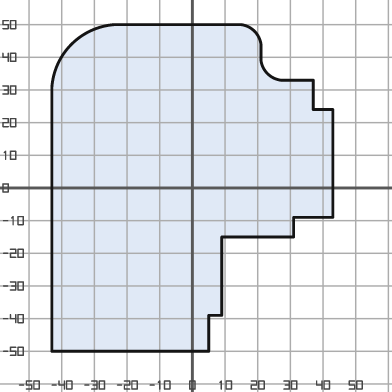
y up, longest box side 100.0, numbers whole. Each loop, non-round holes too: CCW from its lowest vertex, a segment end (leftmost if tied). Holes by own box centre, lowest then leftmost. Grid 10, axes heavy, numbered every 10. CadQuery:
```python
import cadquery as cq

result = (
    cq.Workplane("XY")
    .moveTo(-43.0, -50.0)
    .lineTo(5.0, -50.0)
    .lineTo(5.0, -39.0)
    .lineTo(9.0, -39.0)
    .lineTo(9.0, -15.0)
    .lineTo(31.0, -15.0)
    .lineTo(31.0, -9.0)
    .lineTo(43.0, -9.0)
    .lineTo(43.0, 24.0)
    .lineTo(37.0, 24.0)
    .lineTo(37.0, 33.0)
    .lineTo(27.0, 33.0)
    .threePointArc((23.0, 35.0), (21.0, 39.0))
    .lineTo(21.0, 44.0)
    .threePointArc((19.0, 48.0), (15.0, 50.0))
    .lineTo(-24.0, 50.0)
    .threePointArc((-37.0, 44.0), (-43.0, 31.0))
    .close()
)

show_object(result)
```